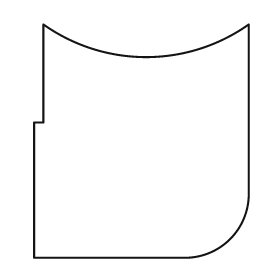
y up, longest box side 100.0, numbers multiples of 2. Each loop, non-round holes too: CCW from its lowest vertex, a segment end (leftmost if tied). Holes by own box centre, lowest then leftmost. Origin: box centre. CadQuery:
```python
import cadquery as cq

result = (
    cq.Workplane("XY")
    .moveTo(-46.0, -50.0)
    .lineTo(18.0, -50.0)
    .threePointArc((38.0, -42.0), (46.0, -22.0))
    .lineTo(46.0, 50.0)
    .threePointArc((2.0, 36.0), (-42.0, 50.0))
    .lineTo(-42.0, 8.0)
    .lineTo(-46.0, 8.0)
    .close()
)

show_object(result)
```